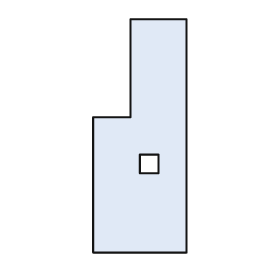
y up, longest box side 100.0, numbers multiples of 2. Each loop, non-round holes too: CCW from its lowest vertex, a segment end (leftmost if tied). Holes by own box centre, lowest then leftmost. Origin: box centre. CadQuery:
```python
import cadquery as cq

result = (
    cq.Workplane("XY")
    .moveTo(-20.0, -50.0)
    .lineTo(20.0, -50.0)
    .lineTo(20.0, 50.0)
    .lineTo(-4.0, 50.0)
    .lineTo(-4.0, 8.0)
    .lineTo(-20.0, 8.0)
    .close()
    .moveTo(0.0, -16.0)
    .lineTo(8.0, -16.0)
    .lineTo(8.0, -8.0)
    .lineTo(0.0, -8.0)
    .close()
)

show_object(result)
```